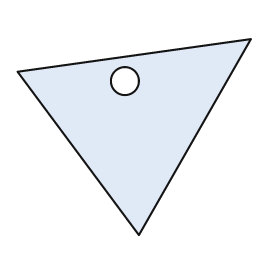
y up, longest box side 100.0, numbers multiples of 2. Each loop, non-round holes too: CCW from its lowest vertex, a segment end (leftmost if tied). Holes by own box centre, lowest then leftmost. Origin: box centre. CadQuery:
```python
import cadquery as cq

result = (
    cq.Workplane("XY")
    .moveTo(2.0, -42.0)
    .lineTo(50.0, 42.0)
    .lineTo(-50.0, 28.0)
    .close()
    .moveTo(-4.0, 24.0)
    .circle(6.0)
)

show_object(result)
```